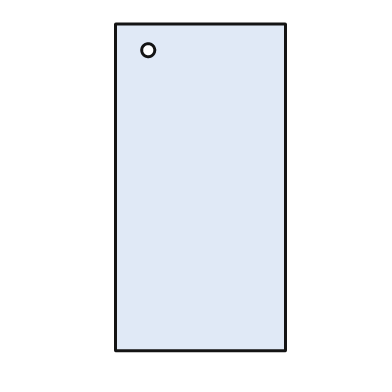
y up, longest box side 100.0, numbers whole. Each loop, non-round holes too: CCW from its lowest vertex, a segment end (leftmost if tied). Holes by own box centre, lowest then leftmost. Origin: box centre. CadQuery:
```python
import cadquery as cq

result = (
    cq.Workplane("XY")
    .moveTo(-26.0, -50.0)
    .lineTo(26.0, -50.0)
    .lineTo(26.0, 50.0)
    .lineTo(-26.0, 50.0)
    .close()
    .moveTo(-16.0, 42.0)
    .circle(2.0)
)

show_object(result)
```